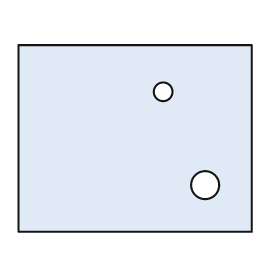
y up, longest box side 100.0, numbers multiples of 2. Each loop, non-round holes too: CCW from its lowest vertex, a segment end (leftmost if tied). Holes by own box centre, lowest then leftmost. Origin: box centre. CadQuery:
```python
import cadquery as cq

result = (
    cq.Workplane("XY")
    .moveTo(-50.0, -40.0)
    .lineTo(50.0, -40.0)
    .lineTo(50.0, 40.0)
    .lineTo(-50.0, 40.0)
    .close()
    .moveTo(30.0, -20.0)
    .circle(6.0)
    .moveTo(12.0, 20.0)
    .circle(4.0)
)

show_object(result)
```